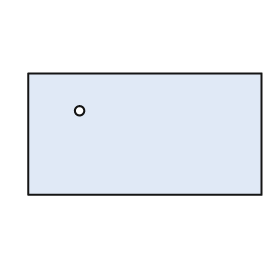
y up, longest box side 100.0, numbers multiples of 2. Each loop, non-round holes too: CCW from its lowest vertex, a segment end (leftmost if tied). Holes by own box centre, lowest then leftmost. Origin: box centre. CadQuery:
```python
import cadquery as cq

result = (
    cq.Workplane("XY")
    .moveTo(-50.0, -26.0)
    .lineTo(50.0, -26.0)
    .lineTo(50.0, 26.0)
    .lineTo(-50.0, 26.0)
    .close()
    .moveTo(-28.0, 10.0)
    .circle(2.0)
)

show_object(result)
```